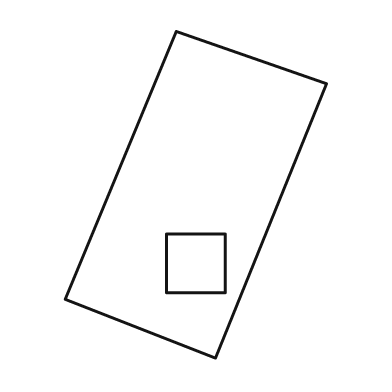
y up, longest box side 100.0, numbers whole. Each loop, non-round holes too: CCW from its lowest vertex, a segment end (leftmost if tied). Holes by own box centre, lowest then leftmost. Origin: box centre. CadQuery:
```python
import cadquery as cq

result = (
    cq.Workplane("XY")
    .moveTo(6.0, -50.0)
    .lineTo(40.0, 34.0)
    .lineTo(-6.0, 50.0)
    .lineTo(-40.0, -32.0)
    .close()
    .moveTo(-9.0, -30.0)
    .lineTo(9.0, -30.0)
    .lineTo(9.0, -12.0)
    .lineTo(-9.0, -12.0)
    .close()
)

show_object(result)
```